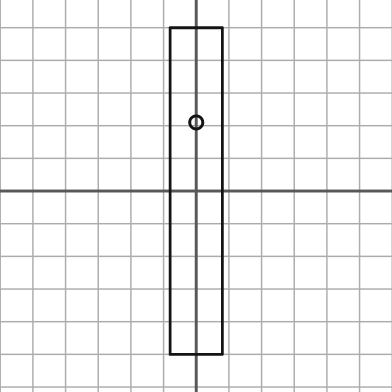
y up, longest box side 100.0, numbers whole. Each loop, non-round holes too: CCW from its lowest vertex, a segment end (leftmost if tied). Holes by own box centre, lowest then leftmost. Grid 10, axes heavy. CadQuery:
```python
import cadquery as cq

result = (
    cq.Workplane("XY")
    .moveTo(-8.0, -50.0)
    .lineTo(8.0, -50.0)
    .lineTo(8.0, 50.0)
    .lineTo(-8.0, 50.0)
    .close()
    .moveTo(0.0, 21.0)
    .circle(2.0)
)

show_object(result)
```